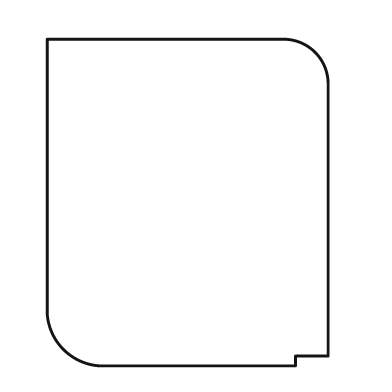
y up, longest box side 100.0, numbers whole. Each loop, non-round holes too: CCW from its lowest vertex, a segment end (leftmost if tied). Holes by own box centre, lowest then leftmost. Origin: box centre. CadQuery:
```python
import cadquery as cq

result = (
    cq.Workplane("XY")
    .moveTo(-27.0, -50.0)
    .lineTo(33.0, -50.0)
    .lineTo(33.0, -47.0)
    .lineTo(43.0, -47.0)
    .lineTo(43.0, 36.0)
    .threePointArc((39.0, 46.0), (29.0, 50.0))
    .lineTo(-43.0, 50.0)
    .lineTo(-43.0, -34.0)
    .threePointArc((-38.0, -45.0), (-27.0, -50.0))
    .close()
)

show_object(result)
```